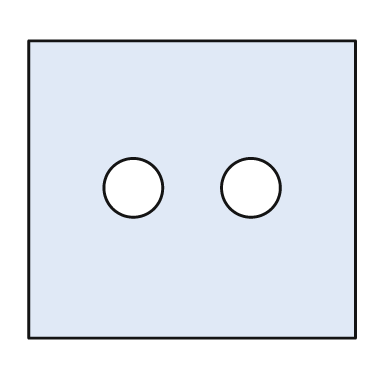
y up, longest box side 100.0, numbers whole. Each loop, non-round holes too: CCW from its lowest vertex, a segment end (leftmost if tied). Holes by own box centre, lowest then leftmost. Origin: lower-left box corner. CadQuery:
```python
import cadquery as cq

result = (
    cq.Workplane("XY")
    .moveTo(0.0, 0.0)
    .lineTo(100.0, 0.0)
    .lineTo(100.0, 91.0)
    .lineTo(0.0, 91.0)
    .close()
    .moveTo(32.0, 46.0)
    .circle(9.0)
    .moveTo(68.0, 46.0)
    .circle(9.0)
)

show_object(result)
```